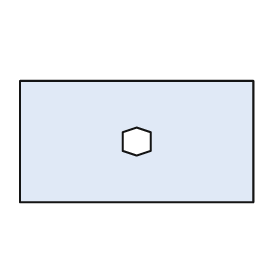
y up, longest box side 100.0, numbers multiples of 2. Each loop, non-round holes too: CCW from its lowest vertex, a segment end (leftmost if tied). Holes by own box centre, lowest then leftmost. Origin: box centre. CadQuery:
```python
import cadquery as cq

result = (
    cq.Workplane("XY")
    .moveTo(-50.0, -26.0)
    .lineTo(50.0, -26.0)
    .lineTo(50.0, 26.0)
    .lineTo(-50.0, 26.0)
    .close()
    .moveTo(0.0, -6.0)
    .lineTo(6.0, -4.0)
    .lineTo(6.0, 4.0)
    .lineTo(0.0, 6.0)
    .lineTo(-6.0, 4.0)
    .lineTo(-6.0, -4.0)
    .close()
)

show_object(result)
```